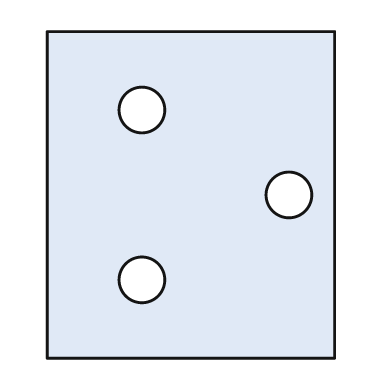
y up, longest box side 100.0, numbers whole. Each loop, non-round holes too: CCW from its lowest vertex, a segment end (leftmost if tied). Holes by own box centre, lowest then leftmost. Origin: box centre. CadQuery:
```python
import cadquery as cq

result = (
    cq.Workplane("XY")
    .moveTo(-44.0, -50.0)
    .lineTo(44.0, -50.0)
    .lineTo(44.0, 50.0)
    .lineTo(-44.0, 50.0)
    .close()
    .moveTo(-15.0, -26.0)
    .circle(7.0)
    .moveTo(30.0, 0.0)
    .circle(7.0)
    .moveTo(-15.0, 26.0)
    .circle(7.0)
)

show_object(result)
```